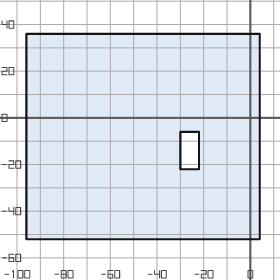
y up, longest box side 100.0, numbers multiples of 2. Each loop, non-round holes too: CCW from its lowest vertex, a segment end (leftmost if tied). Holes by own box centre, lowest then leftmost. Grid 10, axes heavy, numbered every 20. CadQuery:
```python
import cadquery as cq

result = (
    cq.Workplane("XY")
    .moveTo(-96.0, -52.0)
    .lineTo(4.0, -52.0)
    .lineTo(4.0, 36.0)
    .lineTo(-96.0, 36.0)
    .close()
    .moveTo(-30.0, -22.0)
    .lineTo(-22.0, -22.0)
    .lineTo(-22.0, -6.0)
    .lineTo(-30.0, -6.0)
    .close()
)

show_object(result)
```